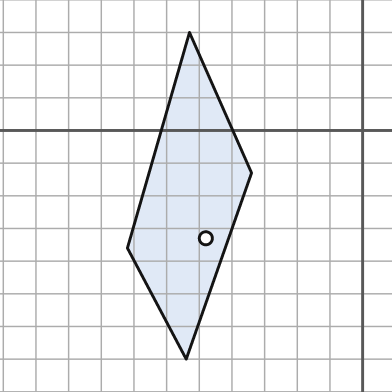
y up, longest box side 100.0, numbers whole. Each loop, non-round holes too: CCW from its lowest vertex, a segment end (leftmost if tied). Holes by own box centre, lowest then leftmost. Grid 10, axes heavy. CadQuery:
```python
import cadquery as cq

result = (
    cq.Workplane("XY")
    .moveTo(-54.0, -70.0)
    .lineTo(-34.0, -13.0)
    .lineTo(-53.0, 30.0)
    .lineTo(-72.0, -36.0)
    .close()
    .moveTo(-48.0, -33.0)
    .circle(2.0)
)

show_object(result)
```